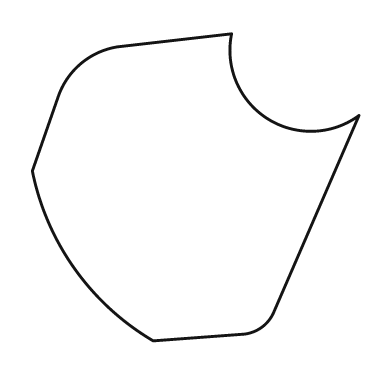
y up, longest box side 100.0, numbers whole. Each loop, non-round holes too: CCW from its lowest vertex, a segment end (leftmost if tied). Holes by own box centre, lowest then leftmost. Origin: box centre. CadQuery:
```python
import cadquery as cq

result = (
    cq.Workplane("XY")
    .moveTo(-13.0, -47.0)
    .lineTo(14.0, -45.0)
    .threePointArc((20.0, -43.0), (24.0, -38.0))
    .lineTo(50.0, 22.0)
    .threePointArc((22.0, 21.0), (11.0, 47.0))
    .lineTo(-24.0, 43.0)
    .threePointArc((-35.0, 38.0), (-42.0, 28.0))
    .lineTo(-50.0, 5.0)
    .threePointArc((-37.0, -25.0), (-13.0, -47.0))
    .close()
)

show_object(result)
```